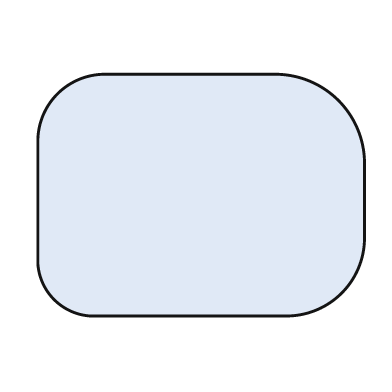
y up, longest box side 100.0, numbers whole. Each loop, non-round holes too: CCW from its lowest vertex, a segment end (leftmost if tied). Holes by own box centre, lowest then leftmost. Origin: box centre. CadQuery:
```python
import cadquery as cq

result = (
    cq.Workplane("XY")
    .moveTo(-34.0, -37.0)
    .lineTo(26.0, -37.0)
    .threePointArc((43.0, -30.0), (50.0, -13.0))
    .lineTo(50.0, 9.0)
    .threePointArc((42.0, 29.0), (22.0, 37.0))
    .lineTo(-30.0, 37.0)
    .threePointArc((-44.0, 31.0), (-50.0, 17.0))
    .lineTo(-50.0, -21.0)
    .threePointArc((-45.0, -32.0), (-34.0, -37.0))
    .close()
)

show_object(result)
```